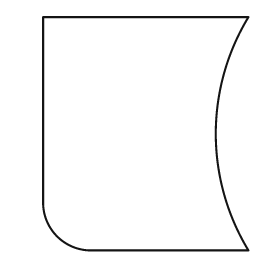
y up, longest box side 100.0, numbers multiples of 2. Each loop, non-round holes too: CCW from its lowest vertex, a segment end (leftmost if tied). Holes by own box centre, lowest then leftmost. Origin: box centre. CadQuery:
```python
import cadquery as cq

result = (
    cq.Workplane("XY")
    .moveTo(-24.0, -50.0)
    .lineTo(44.0, -50.0)
    .threePointArc((30.0, 0.0), (44.0, 50.0))
    .lineTo(-44.0, 50.0)
    .lineTo(-44.0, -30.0)
    .threePointArc((-38.0, -44.0), (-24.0, -50.0))
    .close()
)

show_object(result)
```